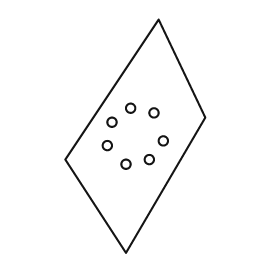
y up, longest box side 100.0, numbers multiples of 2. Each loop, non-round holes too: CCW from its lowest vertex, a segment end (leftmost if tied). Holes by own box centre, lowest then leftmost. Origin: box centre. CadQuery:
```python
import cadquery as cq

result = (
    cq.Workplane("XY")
    .moveTo(-4.0, -50.0)
    .lineTo(30.0, 8.0)
    .lineTo(10.0, 50.0)
    .lineTo(-30.0, -10.0)
    .close()
    .moveTo(-4.0, -12.0)
    .circle(2.0)
    .moveTo(6.0, -10.0)
    .circle(2.0)
    .moveTo(-12.0, -4.0)
    .circle(2.0)
    .moveTo(12.0, -2.0)
    .circle(2.0)
    .moveTo(-10.0, 6.0)
    .circle(2.0)
    .moveTo(8.0, 10.0)
    .circle(2.0)
    .moveTo(-2.0, 12.0)
    .circle(2.0)
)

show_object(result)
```